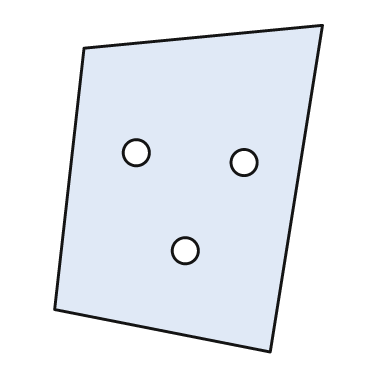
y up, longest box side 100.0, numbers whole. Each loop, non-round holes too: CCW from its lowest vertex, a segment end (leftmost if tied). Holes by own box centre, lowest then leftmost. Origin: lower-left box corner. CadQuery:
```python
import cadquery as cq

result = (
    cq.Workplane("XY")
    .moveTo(66.0, 0.0)
    .lineTo(82.0, 100.0)
    .lineTo(9.0, 93.0)
    .lineTo(0.0, 13.0)
    .close()
    .moveTo(40.0, 31.0)
    .circle(4.0)
    .moveTo(58.0, 58.0)
    .circle(4.0)
    .moveTo(25.0, 61.0)
    .circle(4.0)
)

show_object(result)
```